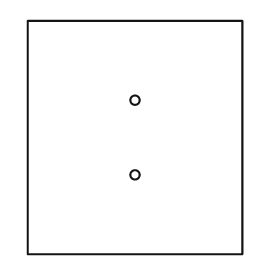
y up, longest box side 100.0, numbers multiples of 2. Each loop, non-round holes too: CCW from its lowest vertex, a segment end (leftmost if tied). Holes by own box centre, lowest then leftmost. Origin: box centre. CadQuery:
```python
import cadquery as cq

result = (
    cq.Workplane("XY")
    .moveTo(-46.0, -50.0)
    .lineTo(46.0, -50.0)
    .lineTo(46.0, 50.0)
    .lineTo(-46.0, 50.0)
    .close()
    .moveTo(0.0, -16.0)
    .circle(2.0)
    .moveTo(0.0, 16.0)
    .circle(2.0)
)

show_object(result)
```